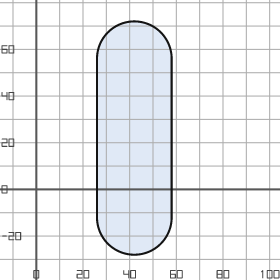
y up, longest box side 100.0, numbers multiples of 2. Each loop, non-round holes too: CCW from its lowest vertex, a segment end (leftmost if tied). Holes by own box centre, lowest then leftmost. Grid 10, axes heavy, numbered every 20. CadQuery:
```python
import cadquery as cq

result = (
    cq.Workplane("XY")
    .moveTo(26.0, -12.0)
    .threePointArc((42.0, -28.0), (58.0, -12.0))
    .lineTo(58.0, 56.0)
    .threePointArc((42.0, 72.0), (26.0, 56.0))
    .close()
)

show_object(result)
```